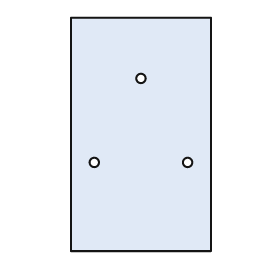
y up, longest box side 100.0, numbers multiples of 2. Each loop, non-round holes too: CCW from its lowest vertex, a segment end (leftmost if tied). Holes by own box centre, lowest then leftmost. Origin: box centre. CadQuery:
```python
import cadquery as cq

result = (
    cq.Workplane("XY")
    .moveTo(-30.0, -50.0)
    .lineTo(30.0, -50.0)
    .lineTo(30.0, 50.0)
    .lineTo(-30.0, 50.0)
    .close()
    .moveTo(-20.0, -12.0)
    .circle(2.0)
    .moveTo(20.0, -12.0)
    .circle(2.0)
    .moveTo(0.0, 24.0)
    .circle(2.0)
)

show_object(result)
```